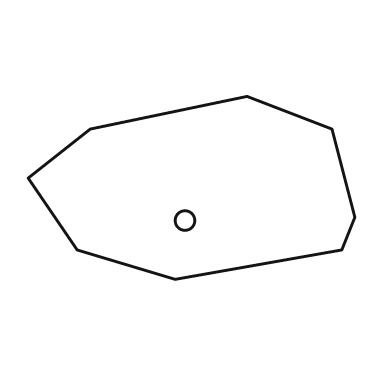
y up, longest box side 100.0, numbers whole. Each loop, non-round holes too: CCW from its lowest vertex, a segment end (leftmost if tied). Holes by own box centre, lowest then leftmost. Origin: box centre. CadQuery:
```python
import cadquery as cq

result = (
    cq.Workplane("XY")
    .moveTo(-5.0, -28.0)
    .lineTo(46.0, -19.0)
    .lineTo(50.0, -9.0)
    .lineTo(43.0, 18.0)
    .lineTo(17.0, 28.0)
    .lineTo(-31.0, 18.0)
    .lineTo(-50.0, 3.0)
    .lineTo(-35.0, -19.0)
    .close()
    .moveTo(-2.0, -10.0)
    .circle(3.0)
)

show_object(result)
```